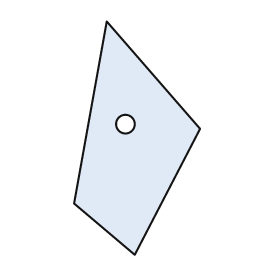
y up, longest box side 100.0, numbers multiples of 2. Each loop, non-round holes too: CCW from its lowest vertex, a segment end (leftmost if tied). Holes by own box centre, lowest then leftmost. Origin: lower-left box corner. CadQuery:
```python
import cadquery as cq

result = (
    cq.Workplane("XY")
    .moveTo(26.0, 0.0)
    .lineTo(54.0, 54.0)
    .lineTo(14.0, 100.0)
    .lineTo(0.0, 22.0)
    .close()
    .moveTo(22.0, 56.0)
    .circle(4.0)
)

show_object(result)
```